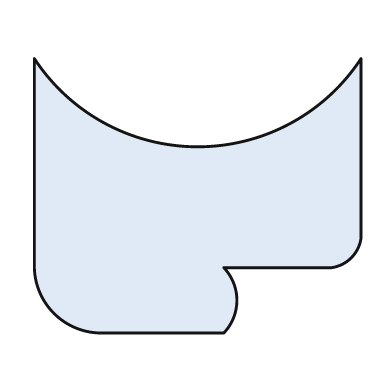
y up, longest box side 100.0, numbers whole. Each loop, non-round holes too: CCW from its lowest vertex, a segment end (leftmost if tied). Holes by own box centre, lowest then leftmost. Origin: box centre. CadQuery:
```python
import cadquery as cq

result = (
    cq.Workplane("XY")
    .moveTo(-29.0, -42.0)
    .lineTo(8.0, -42.0)
    .threePointArc((12.0, -32.0), (8.0, -22.0))
    .lineTo(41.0, -22.0)
    .threePointArc((47.0, -19.0), (50.0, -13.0))
    .lineTo(50.0, 42.0)
    .threePointArc((0.0, 15.0), (-50.0, 42.0))
    .lineTo(-50.0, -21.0)
    .threePointArc((-44.0, -36.0), (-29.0, -42.0))
    .close()
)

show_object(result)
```